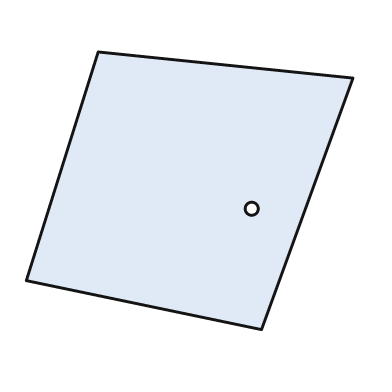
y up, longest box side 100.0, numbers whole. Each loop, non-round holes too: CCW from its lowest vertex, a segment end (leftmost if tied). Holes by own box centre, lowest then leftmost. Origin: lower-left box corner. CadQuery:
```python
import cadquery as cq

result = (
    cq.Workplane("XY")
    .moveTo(72.0, 0.0)
    .lineTo(100.0, 77.0)
    .lineTo(22.0, 85.0)
    .lineTo(0.0, 15.0)
    .close()
    .moveTo(69.0, 37.0)
    .circle(2.0)
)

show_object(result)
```